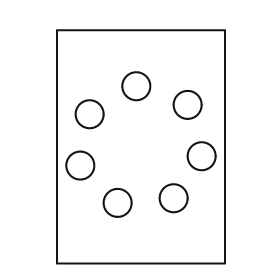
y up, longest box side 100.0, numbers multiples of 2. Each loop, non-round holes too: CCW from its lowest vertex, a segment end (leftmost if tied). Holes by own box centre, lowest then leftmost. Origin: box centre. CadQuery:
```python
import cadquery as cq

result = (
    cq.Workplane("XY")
    .moveTo(-36.0, -50.0)
    .lineTo(36.0, -50.0)
    .lineTo(36.0, 50.0)
    .lineTo(-36.0, 50.0)
    .close()
    .moveTo(-10.0, -24.0)
    .circle(6.0)
    .moveTo(14.0, -22.0)
    .circle(6.0)
    .moveTo(-26.0, -8.0)
    .circle(6.0)
    .moveTo(26.0, -4.0)
    .circle(6.0)
    .moveTo(-22.0, 14.0)
    .circle(6.0)
    .moveTo(20.0, 18.0)
    .circle(6.0)
    .moveTo(-2.0, 26.0)
    .circle(6.0)
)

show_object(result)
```